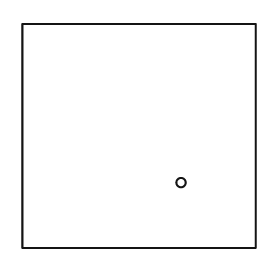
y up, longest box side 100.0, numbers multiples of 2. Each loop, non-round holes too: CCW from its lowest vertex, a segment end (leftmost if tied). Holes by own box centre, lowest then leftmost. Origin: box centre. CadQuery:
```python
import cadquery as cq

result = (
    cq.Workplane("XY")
    .moveTo(-50.0, -48.0)
    .lineTo(50.0, -48.0)
    .lineTo(50.0, 48.0)
    .lineTo(-50.0, 48.0)
    .close()
    .moveTo(18.0, -20.0)
    .circle(2.0)
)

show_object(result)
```